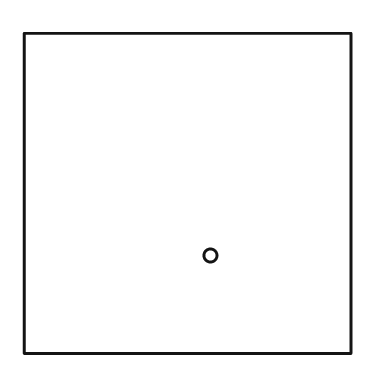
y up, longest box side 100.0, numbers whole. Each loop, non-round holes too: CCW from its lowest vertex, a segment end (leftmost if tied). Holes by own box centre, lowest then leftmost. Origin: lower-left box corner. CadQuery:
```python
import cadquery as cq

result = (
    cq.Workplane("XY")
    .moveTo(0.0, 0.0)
    .lineTo(100.0, 0.0)
    .lineTo(100.0, 98.0)
    .lineTo(0.0, 98.0)
    .close()
    .moveTo(57.0, 30.0)
    .circle(2.0)
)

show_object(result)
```